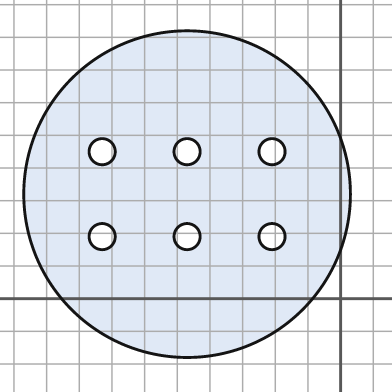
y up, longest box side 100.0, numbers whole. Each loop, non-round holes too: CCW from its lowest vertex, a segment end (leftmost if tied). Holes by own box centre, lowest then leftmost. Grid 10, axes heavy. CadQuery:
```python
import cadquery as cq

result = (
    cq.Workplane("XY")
    .moveTo(-47.0, 32.0)
    .circle(50.0)
    .moveTo(-73.0, 19.0)
    .circle(4.0)
    .moveTo(-47.0, 19.0)
    .circle(4.0)
    .moveTo(-21.0, 19.0)
    .circle(4.0)
    .moveTo(-73.0, 45.0)
    .circle(4.0)
    .moveTo(-47.0, 45.0)
    .circle(4.0)
    .moveTo(-21.0, 45.0)
    .circle(4.0)
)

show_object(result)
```